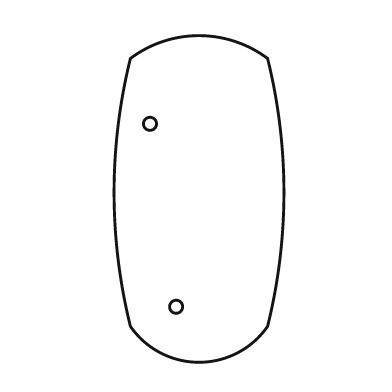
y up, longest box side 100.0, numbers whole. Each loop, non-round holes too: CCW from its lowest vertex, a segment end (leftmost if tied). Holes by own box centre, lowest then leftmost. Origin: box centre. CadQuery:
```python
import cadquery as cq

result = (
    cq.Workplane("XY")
    .moveTo(-21.0, -39.0)
    .threePointArc((0.0, -50.0), (21.0, -39.0))
    .threePointArc((26.0, 2.0), (21.0, 43.0))
    .threePointArc((0.0, 50.0), (-21.0, 43.0))
    .threePointArc((-26.0, 2.0), (-21.0, -39.0))
    .close()
    .moveTo(-7.0, -33.0)
    .circle(2.0)
    .moveTo(-15.0, 23.0)
    .circle(2.0)
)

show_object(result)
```